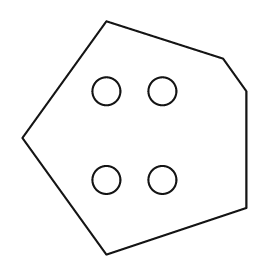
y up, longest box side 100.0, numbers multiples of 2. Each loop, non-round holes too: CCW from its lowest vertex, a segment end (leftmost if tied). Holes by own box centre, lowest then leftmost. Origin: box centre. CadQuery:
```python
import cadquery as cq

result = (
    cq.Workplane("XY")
    .moveTo(-12.0, -50.0)
    .lineTo(48.0, -30.0)
    .lineTo(48.0, 20.0)
    .lineTo(38.0, 34.0)
    .lineTo(-12.0, 50.0)
    .lineTo(-48.0, 0.0)
    .close()
    .moveTo(-12.0, -18.0)
    .circle(6.0)
    .moveTo(12.0, -18.0)
    .circle(6.0)
    .moveTo(-12.0, 20.0)
    .circle(6.0)
    .moveTo(12.0, 20.0)
    .circle(6.0)
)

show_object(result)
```